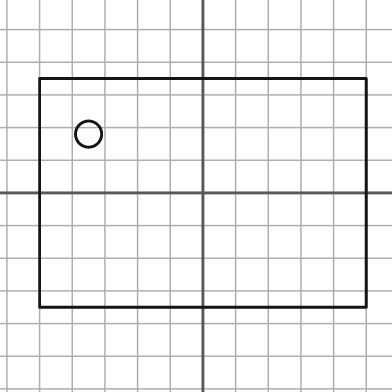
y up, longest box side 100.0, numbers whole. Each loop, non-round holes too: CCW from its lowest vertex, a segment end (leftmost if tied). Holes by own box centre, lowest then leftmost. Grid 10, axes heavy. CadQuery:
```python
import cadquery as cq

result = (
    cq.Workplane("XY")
    .moveTo(-50.0, -35.0)
    .lineTo(50.0, -35.0)
    .lineTo(50.0, 35.0)
    .lineTo(-50.0, 35.0)
    .close()
    .moveTo(-35.0, 18.0)
    .circle(4.0)
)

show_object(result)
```